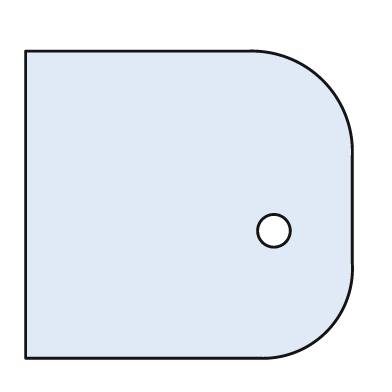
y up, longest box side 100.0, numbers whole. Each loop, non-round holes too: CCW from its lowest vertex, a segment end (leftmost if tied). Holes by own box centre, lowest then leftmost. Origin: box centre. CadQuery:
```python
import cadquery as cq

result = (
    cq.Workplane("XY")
    .moveTo(-50.0, -47.0)
    .lineTo(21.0, -47.0)
    .threePointArc((42.0, -39.0), (50.0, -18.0))
    .lineTo(50.0, 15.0)
    .threePointArc((41.0, 38.0), (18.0, 47.0))
    .lineTo(-50.0, 47.0)
    .close()
    .moveTo(26.0, -8.0)
    .circle(5.0)
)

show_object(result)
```